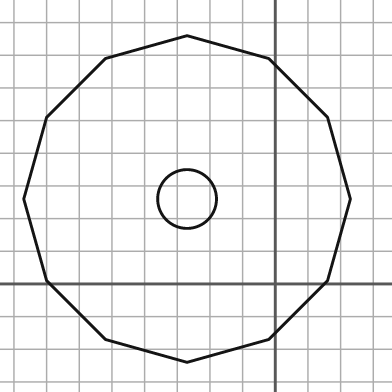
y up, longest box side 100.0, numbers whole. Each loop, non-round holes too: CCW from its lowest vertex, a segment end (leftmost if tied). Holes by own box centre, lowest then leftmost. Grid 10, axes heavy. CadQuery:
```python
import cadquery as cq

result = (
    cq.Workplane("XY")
    .moveTo(-27.0, -24.0)
    .lineTo(-2.0, -17.0)
    .lineTo(16.0, 1.0)
    .lineTo(23.0, 26.0)
    .lineTo(16.0, 51.0)
    .lineTo(-2.0, 69.0)
    .lineTo(-27.0, 76.0)
    .lineTo(-52.0, 69.0)
    .lineTo(-70.0, 51.0)
    .lineTo(-77.0, 26.0)
    .lineTo(-70.0, 1.0)
    .lineTo(-52.0, -17.0)
    .close()
    .moveTo(-27.0, 26.0)
    .circle(9.0)
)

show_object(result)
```